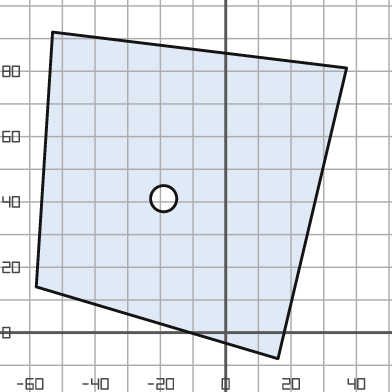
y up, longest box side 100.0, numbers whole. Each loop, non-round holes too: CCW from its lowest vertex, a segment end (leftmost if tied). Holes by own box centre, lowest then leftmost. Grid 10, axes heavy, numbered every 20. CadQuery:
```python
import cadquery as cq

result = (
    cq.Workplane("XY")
    .moveTo(16.0, -8.0)
    .lineTo(37.0, 81.0)
    .lineTo(-53.0, 92.0)
    .lineTo(-58.0, 14.0)
    .close()
    .moveTo(-19.0, 41.0)
    .circle(4.0)
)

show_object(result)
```